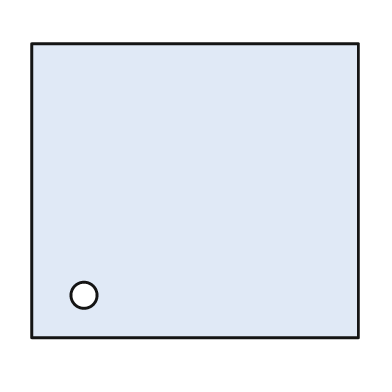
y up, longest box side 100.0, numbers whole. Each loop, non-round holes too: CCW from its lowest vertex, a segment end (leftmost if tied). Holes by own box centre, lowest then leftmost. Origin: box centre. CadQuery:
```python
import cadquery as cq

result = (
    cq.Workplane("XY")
    .moveTo(-50.0, -45.0)
    .lineTo(50.0, -45.0)
    .lineTo(50.0, 45.0)
    .lineTo(-50.0, 45.0)
    .close()
    .moveTo(-34.0, -32.0)
    .circle(4.0)
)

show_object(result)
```